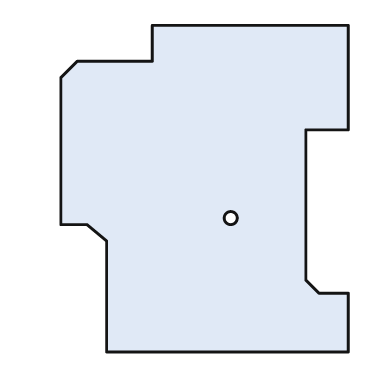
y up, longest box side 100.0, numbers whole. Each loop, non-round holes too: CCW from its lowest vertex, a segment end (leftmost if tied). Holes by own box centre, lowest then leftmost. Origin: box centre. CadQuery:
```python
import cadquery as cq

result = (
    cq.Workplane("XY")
    .moveTo(-30.0, -50.0)
    .lineTo(44.0, -50.0)
    .lineTo(44.0, -32.0)
    .lineTo(35.0, -32.0)
    .lineTo(31.0, -28.0)
    .lineTo(31.0, 18.0)
    .lineTo(44.0, 18.0)
    .lineTo(44.0, 50.0)
    .lineTo(-16.0, 50.0)
    .lineTo(-16.0, 39.0)
    .lineTo(-39.0, 39.0)
    .lineTo(-44.0, 34.0)
    .lineTo(-44.0, -11.0)
    .lineTo(-36.0, -11.0)
    .lineTo(-30.0, -16.0)
    .close()
    .moveTo(8.0, -9.0)
    .circle(2.0)
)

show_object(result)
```